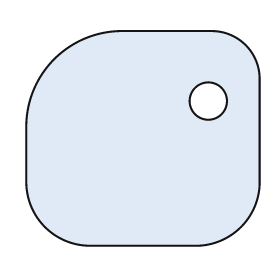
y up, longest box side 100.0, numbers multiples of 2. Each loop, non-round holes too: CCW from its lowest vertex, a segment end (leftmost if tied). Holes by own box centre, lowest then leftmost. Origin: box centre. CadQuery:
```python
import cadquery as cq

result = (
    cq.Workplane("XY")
    .moveTo(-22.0, -46.0)
    .lineTo(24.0, -46.0)
    .threePointArc((42.0, -38.0), (50.0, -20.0))
    .lineTo(50.0, 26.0)
    .threePointArc((44.0, 40.0), (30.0, 46.0))
    .lineTo(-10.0, 46.0)
    .threePointArc((-38.0, 34.0), (-50.0, 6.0))
    .lineTo(-50.0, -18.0)
    .threePointArc((-42.0, -38.0), (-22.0, -46.0))
    .close()
    .moveTo(28.0, 16.0)
    .circle(8.0)
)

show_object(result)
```